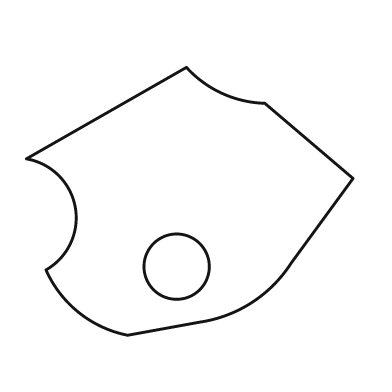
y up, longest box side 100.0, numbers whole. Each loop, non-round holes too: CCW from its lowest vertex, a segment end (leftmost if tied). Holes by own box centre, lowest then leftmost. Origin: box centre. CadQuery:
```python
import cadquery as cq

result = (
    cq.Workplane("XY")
    .moveTo(-19.0, -41.0)
    .lineTo(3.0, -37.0)
    .threePointArc((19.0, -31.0), (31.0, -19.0))
    .lineTo(50.0, 7.0)
    .lineTo(23.0, 30.0)
    .threePointArc((10.0, 33.0), (-1.0, 41.0))
    .lineTo(-50.0, 13.0)
    .threePointArc((-35.0, -2.0), (-44.0, -21.0))
    .threePointArc((-34.0, -34.0), (-19.0, -41.0))
    .close()
    .moveTo(-4.0, -20.0)
    .circle(10.0)
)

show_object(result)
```